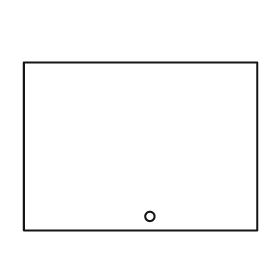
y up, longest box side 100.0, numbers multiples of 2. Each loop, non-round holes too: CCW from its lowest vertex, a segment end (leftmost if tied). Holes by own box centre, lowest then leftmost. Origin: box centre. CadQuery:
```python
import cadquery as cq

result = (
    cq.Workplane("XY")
    .moveTo(-50.0, -36.0)
    .lineTo(50.0, -36.0)
    .lineTo(50.0, 36.0)
    .lineTo(-50.0, 36.0)
    .close()
    .moveTo(4.0, -30.0)
    .circle(2.0)
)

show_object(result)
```